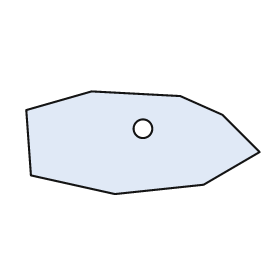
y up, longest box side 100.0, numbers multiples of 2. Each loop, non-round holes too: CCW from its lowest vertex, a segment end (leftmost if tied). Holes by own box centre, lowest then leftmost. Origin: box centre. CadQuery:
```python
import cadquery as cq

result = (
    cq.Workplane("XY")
    .moveTo(-12.0, -22.0)
    .lineTo(26.0, -18.0)
    .lineTo(50.0, -4.0)
    .lineTo(34.0, 12.0)
    .lineTo(16.0, 20.0)
    .lineTo(-22.0, 22.0)
    .lineTo(-50.0, 14.0)
    .lineTo(-48.0, -14.0)
    .close()
    .moveTo(0.0, 6.0)
    .circle(4.0)
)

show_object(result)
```